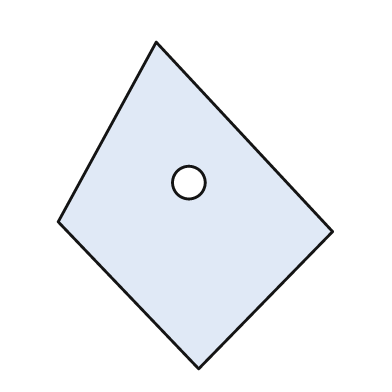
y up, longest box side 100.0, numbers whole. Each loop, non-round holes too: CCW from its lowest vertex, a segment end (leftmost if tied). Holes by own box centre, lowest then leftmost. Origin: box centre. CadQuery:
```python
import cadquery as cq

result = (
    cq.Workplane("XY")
    .moveTo(1.0, -50.0)
    .lineTo(42.0, -8.0)
    .lineTo(-12.0, 50.0)
    .lineTo(-42.0, -5.0)
    .close()
    .moveTo(-2.0, 7.0)
    .circle(5.0)
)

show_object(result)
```